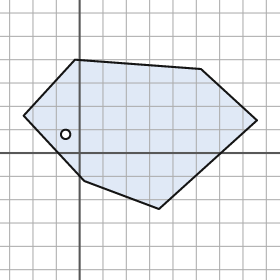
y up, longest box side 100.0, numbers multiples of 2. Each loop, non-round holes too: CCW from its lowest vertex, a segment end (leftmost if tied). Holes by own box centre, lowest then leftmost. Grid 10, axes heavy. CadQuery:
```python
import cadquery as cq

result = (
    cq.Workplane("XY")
    .moveTo(34.0, -24.0)
    .lineTo(76.0, 14.0)
    .lineTo(52.0, 36.0)
    .lineTo(-2.0, 40.0)
    .lineTo(-24.0, 16.0)
    .lineTo(2.0, -12.0)
    .close()
    .moveTo(-6.0, 8.0)
    .circle(2.0)
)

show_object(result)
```